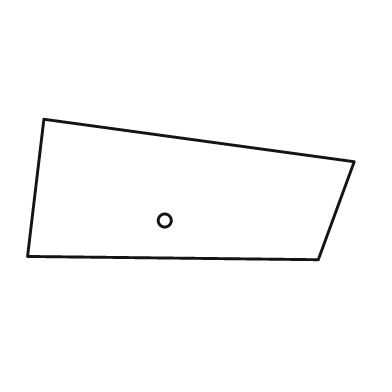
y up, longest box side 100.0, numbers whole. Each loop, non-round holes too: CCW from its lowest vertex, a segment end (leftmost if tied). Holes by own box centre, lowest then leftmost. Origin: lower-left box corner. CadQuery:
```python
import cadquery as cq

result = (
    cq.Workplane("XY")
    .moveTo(89.0, 0.0)
    .lineTo(100.0, 30.0)
    .lineTo(5.0, 43.0)
    .lineTo(0.0, 1.0)
    .close()
    .moveTo(42.0, 12.0)
    .circle(2.0)
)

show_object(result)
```